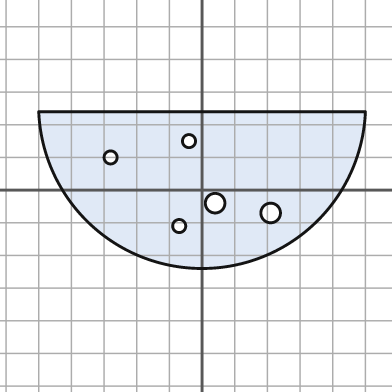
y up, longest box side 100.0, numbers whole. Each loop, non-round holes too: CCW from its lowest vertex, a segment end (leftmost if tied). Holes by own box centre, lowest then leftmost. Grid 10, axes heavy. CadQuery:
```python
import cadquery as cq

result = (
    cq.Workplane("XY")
    .moveTo(-50.0, 24.0)
    .threePointArc((0.0, -24.0), (50.0, 24.0))
    .close()
    .moveTo(-7.0, -11.0)
    .circle(2.0)
    .moveTo(21.0, -7.0)
    .circle(3.0)
    .moveTo(4.0, -4.0)
    .circle(3.0)
    .moveTo(-28.0, 10.0)
    .circle(2.0)
    .moveTo(-4.0, 15.0)
    .circle(2.0)
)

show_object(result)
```